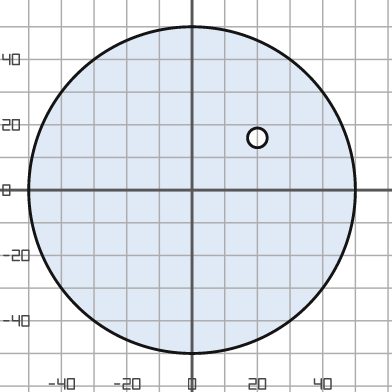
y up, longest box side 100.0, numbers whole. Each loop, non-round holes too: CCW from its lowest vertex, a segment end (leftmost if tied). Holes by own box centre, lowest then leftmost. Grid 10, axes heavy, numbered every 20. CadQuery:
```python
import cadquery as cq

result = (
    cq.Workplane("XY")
    .moveTo(0.0, 0.0)
    .circle(50.0)
    .moveTo(20.0, 16.0)
    .circle(3.0)
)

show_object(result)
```